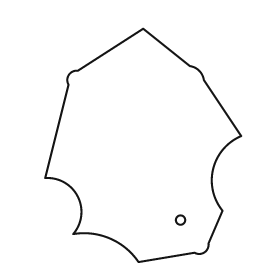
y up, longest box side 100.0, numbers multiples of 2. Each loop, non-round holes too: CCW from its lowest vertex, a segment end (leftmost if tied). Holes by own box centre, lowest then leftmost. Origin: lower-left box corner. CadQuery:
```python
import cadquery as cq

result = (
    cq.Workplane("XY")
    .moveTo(40.0, 0.0)
    .lineTo(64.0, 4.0)
    .threePointArc((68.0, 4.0), (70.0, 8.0))
    .lineTo(76.0, 22.0)
    .threePointArc((72.0, 40.0), (84.0, 54.0))
    .lineTo(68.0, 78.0)
    .threePointArc((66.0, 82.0), (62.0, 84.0))
    .lineTo(42.0, 100.0)
    .lineTo(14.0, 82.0)
    .threePointArc((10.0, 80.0), (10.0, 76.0))
    .lineTo(0.0, 36.0)
    .threePointArc((14.0, 28.0), (12.0, 12.0))
    .threePointArc((28.0, 10.0), (40.0, 0.0))
    .close()
    .moveTo(58.0, 18.0)
    .circle(2.0)
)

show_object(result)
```